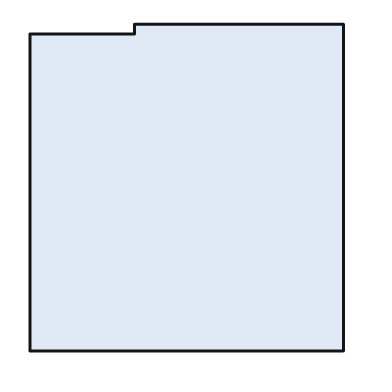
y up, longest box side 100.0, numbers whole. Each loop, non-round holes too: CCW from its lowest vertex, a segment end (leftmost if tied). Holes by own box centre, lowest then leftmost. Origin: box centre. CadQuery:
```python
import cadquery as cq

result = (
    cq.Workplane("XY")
    .moveTo(-48.0, -50.0)
    .lineTo(48.0, -50.0)
    .lineTo(48.0, 50.0)
    .lineTo(-16.0, 50.0)
    .lineTo(-16.0, 47.0)
    .lineTo(-48.0, 47.0)
    .close()
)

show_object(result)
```